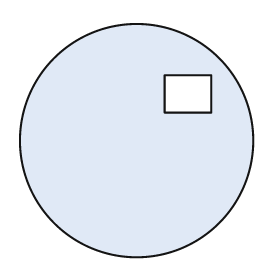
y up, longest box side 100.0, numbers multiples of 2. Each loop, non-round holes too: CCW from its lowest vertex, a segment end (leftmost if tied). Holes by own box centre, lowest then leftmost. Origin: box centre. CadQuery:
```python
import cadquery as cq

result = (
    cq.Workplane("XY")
    .moveTo(0.0, 0.0)
    .circle(50.0)
    .moveTo(12.0, 12.0)
    .lineTo(32.0, 12.0)
    .lineTo(32.0, 28.0)
    .lineTo(12.0, 28.0)
    .close()
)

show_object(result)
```